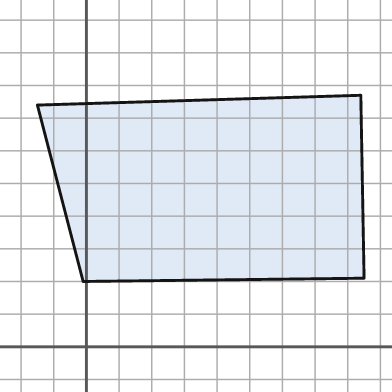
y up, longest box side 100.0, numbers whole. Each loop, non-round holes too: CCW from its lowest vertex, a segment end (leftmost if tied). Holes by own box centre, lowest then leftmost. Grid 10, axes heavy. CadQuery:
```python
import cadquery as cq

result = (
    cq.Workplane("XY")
    .moveTo(-1.0, 20.0)
    .lineTo(85.0, 21.0)
    .lineTo(84.0, 77.0)
    .lineTo(-15.0, 74.0)
    .close()
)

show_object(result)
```